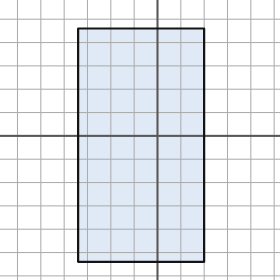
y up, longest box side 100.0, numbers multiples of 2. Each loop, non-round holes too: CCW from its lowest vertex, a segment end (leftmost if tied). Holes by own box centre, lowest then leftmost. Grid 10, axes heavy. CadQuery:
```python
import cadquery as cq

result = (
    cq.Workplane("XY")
    .moveTo(-34.0, -54.0)
    .lineTo(20.0, -54.0)
    .lineTo(20.0, 46.0)
    .lineTo(-34.0, 46.0)
    .close()
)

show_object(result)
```